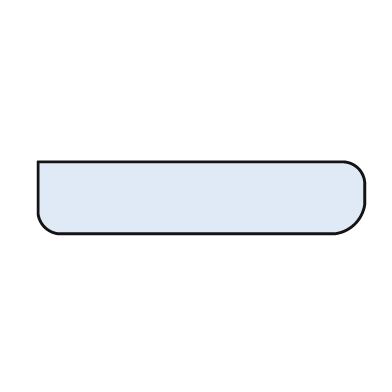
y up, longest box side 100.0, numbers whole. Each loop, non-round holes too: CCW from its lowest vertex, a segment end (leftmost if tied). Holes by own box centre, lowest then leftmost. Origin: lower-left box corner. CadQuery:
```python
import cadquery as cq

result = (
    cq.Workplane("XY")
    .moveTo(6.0, 0.0)
    .lineTo(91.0, 0.0)
    .threePointArc((97.0, 3.0), (100.0, 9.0))
    .lineTo(100.0, 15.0)
    .threePointArc((98.0, 20.0), (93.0, 22.0))
    .lineTo(0.0, 22.0)
    .lineTo(0.0, 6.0)
    .threePointArc((2.0, 2.0), (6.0, 0.0))
    .close()
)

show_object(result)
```